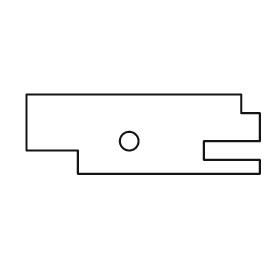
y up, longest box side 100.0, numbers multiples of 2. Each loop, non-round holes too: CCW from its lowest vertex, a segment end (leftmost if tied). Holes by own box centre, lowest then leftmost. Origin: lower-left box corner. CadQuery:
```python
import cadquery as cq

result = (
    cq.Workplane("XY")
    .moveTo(22.0, 0.0)
    .lineTo(100.0, 0.0)
    .lineTo(100.0, 6.0)
    .lineTo(76.0, 6.0)
    .lineTo(76.0, 14.0)
    .lineTo(100.0, 14.0)
    .lineTo(100.0, 26.0)
    .lineTo(92.0, 26.0)
    .lineTo(92.0, 34.0)
    .lineTo(0.0, 34.0)
    .lineTo(0.0, 10.0)
    .lineTo(22.0, 10.0)
    .close()
    .moveTo(44.0, 14.0)
    .circle(4.0)
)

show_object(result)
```